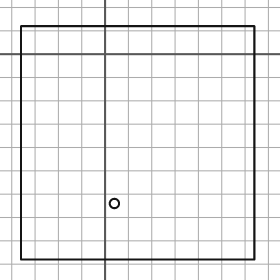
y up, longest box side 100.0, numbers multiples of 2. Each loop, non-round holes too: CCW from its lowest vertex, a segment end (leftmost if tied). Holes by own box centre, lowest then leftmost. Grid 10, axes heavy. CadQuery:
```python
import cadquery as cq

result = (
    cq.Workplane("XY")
    .moveTo(-36.0, -88.0)
    .lineTo(64.0, -88.0)
    .lineTo(64.0, 12.0)
    .lineTo(-36.0, 12.0)
    .close()
    .moveTo(4.0, -64.0)
    .circle(2.0)
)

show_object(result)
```